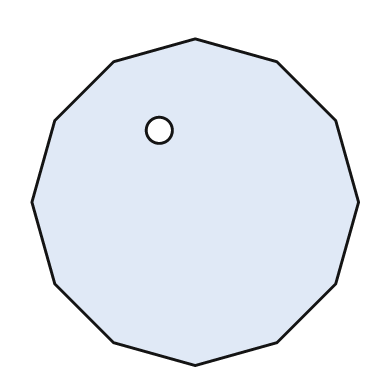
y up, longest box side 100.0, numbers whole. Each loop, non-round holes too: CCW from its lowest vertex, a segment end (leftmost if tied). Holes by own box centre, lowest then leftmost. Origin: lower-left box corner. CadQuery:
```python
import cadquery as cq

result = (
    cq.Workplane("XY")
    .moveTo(50.0, 0.0)
    .lineTo(75.0, 7.0)
    .lineTo(93.0, 25.0)
    .lineTo(100.0, 50.0)
    .lineTo(93.0, 75.0)
    .lineTo(75.0, 93.0)
    .lineTo(50.0, 100.0)
    .lineTo(25.0, 93.0)
    .lineTo(7.0, 75.0)
    .lineTo(0.0, 50.0)
    .lineTo(7.0, 25.0)
    .lineTo(25.0, 7.0)
    .close()
    .moveTo(39.0, 72.0)
    .circle(4.0)
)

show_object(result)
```